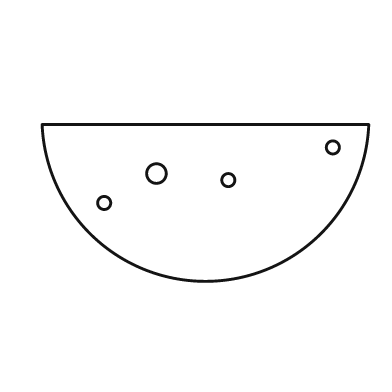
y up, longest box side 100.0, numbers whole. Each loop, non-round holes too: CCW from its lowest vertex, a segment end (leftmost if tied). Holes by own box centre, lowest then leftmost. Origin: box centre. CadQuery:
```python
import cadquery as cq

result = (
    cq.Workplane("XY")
    .moveTo(-50.0, 24.0)
    .threePointArc((0.0, -24.0), (50.0, 24.0))
    .close()
    .moveTo(-31.0, 0.0)
    .circle(2.0)
    .moveTo(7.0, 7.0)
    .circle(2.0)
    .moveTo(-15.0, 9.0)
    .circle(3.0)
    .moveTo(39.0, 17.0)
    .circle(2.0)
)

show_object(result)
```